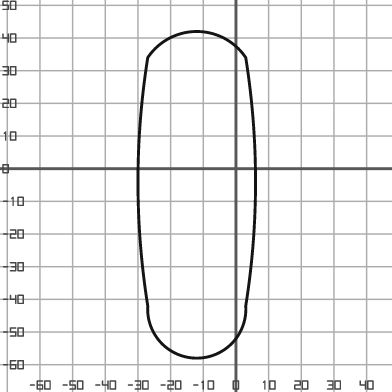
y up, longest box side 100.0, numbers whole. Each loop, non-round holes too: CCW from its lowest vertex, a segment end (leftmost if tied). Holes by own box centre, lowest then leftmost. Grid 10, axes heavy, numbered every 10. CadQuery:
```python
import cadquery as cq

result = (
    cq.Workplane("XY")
    .moveTo(-27.0, -42.0)
    .threePointArc((-12.0, -58.0), (3.0, -42.0))
    .threePointArc((6.0, -4.0), (3.0, 34.0))
    .threePointArc((-12.0, 42.0), (-27.0, 34.0))
    .threePointArc((-30.0, -4.0), (-27.0, -42.0))
    .close()
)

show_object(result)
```